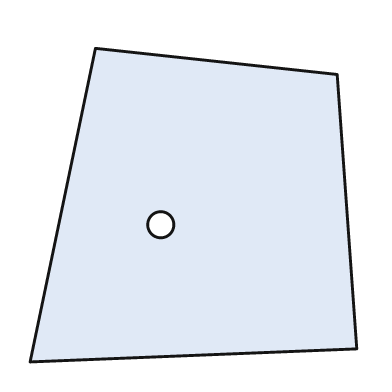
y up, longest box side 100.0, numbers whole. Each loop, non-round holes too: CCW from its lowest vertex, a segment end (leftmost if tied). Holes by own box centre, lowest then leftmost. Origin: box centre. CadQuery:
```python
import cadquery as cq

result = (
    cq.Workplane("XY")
    .moveTo(-50.0, -48.0)
    .lineTo(50.0, -44.0)
    .lineTo(44.0, 40.0)
    .lineTo(-30.0, 48.0)
    .close()
    .moveTo(-10.0, -6.0)
    .circle(4.0)
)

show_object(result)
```